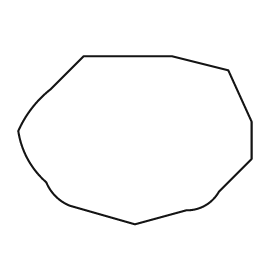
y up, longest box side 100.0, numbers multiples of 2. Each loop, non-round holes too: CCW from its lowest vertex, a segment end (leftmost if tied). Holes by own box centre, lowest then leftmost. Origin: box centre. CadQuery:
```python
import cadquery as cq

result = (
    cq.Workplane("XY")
    .moveTo(0.0, -36.0)
    .lineTo(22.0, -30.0)
    .threePointArc((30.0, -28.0), (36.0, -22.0))
    .lineTo(50.0, -8.0)
    .lineTo(50.0, 8.0)
    .lineTo(40.0, 30.0)
    .lineTo(16.0, 36.0)
    .lineTo(-22.0, 36.0)
    .lineTo(-36.0, 22.0)
    .threePointArc((-44.0, 14.0), (-50.0, 4.0))
    .threePointArc((-46.0, -8.0), (-38.0, -18.0))
    .threePointArc((-34.0, -24.0), (-28.0, -28.0))
    .close()
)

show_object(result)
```